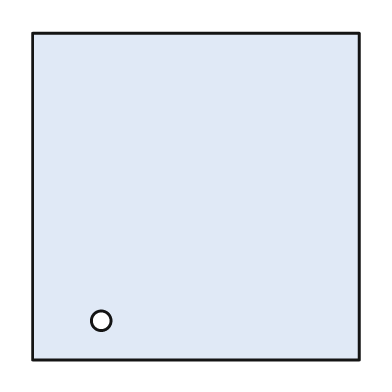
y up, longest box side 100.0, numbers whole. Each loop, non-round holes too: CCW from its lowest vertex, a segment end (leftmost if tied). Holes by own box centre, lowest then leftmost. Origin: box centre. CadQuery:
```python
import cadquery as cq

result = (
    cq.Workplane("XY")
    .moveTo(-50.0, -50.0)
    .lineTo(50.0, -50.0)
    .lineTo(50.0, 50.0)
    .lineTo(-50.0, 50.0)
    .close()
    .moveTo(-29.0, -38.0)
    .circle(3.0)
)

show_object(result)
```